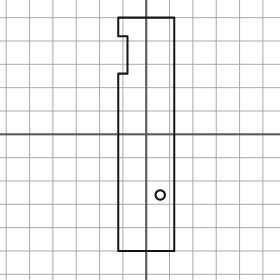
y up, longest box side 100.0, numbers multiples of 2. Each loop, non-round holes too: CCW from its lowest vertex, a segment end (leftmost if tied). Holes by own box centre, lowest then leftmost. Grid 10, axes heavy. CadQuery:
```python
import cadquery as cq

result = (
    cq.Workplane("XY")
    .moveTo(-12.0, -50.0)
    .lineTo(12.0, -50.0)
    .lineTo(12.0, 50.0)
    .lineTo(-12.0, 50.0)
    .lineTo(-12.0, 42.0)
    .lineTo(-8.0, 42.0)
    .lineTo(-8.0, 26.0)
    .lineTo(-12.0, 26.0)
    .close()
    .moveTo(6.0, -26.0)
    .circle(2.0)
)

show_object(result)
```